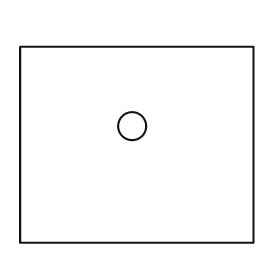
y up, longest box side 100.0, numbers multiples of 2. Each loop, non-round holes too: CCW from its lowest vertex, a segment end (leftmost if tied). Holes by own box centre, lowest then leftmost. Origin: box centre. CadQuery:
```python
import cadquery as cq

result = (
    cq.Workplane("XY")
    .moveTo(-50.0, -42.0)
    .lineTo(50.0, -42.0)
    .lineTo(50.0, 42.0)
    .lineTo(-50.0, 42.0)
    .close()
    .moveTo(-2.0, 8.0)
    .circle(6.0)
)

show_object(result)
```